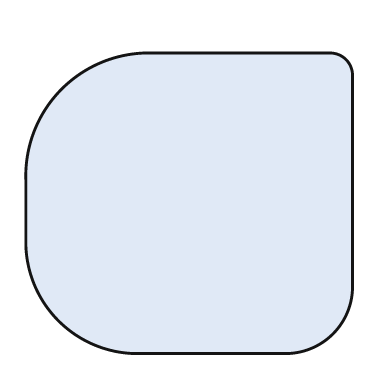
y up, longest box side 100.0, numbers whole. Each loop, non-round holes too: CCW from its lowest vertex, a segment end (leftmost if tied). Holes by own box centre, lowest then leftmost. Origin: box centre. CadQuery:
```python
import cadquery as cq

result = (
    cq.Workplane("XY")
    .moveTo(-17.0, -46.0)
    .lineTo(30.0, -46.0)
    .threePointArc((44.0, -40.0), (50.0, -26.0))
    .lineTo(50.0, 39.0)
    .threePointArc((48.0, 44.0), (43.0, 46.0))
    .lineTo(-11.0, 46.0)
    .threePointArc((-39.0, 35.0), (-50.0, 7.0))
    .lineTo(-50.0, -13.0)
    .threePointArc((-40.0, -36.0), (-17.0, -46.0))
    .close()
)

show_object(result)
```